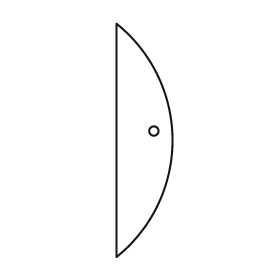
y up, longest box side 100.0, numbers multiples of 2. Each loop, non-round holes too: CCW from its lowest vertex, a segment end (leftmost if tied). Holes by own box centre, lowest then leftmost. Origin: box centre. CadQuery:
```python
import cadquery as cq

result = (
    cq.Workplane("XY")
    .moveTo(-12.0, -50.0)
    .threePointArc((12.0, 0.0), (-12.0, 50.0))
    .close()
    .moveTo(4.0, 4.0)
    .circle(2.0)
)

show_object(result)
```